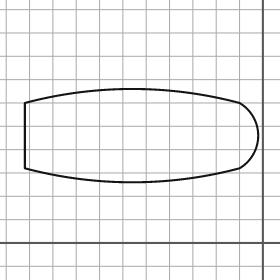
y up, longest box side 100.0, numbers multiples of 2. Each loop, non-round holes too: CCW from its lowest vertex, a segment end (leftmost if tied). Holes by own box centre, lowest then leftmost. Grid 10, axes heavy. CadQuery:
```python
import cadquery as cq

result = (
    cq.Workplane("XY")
    .moveTo(-102.0, 32.0)
    .threePointArc((-56.0, 26.0), (-10.0, 32.0))
    .threePointArc((-2.0, 46.0), (-10.0, 60.0))
    .threePointArc((-56.0, 66.0), (-102.0, 60.0))
    .close()
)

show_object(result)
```